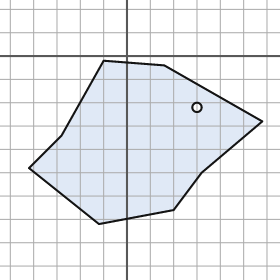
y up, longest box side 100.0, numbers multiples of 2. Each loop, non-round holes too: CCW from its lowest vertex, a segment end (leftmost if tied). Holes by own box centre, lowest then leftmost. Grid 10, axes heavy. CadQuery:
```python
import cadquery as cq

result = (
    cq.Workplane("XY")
    .moveTo(-12.0, -72.0)
    .lineTo(20.0, -66.0)
    .lineTo(32.0, -50.0)
    .lineTo(58.0, -28.0)
    .lineTo(16.0, -4.0)
    .lineTo(-10.0, -2.0)
    .lineTo(-28.0, -34.0)
    .lineTo(-42.0, -48.0)
    .close()
    .moveTo(30.0, -22.0)
    .circle(2.0)
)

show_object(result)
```